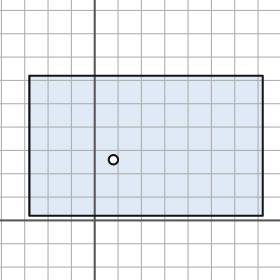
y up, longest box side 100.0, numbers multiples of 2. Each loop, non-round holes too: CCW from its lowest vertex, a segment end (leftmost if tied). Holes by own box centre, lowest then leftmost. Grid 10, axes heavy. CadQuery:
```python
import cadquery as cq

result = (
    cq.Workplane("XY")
    .moveTo(-28.0, 2.0)
    .lineTo(72.0, 2.0)
    .lineTo(72.0, 62.0)
    .lineTo(-28.0, 62.0)
    .close()
    .moveTo(8.0, 26.0)
    .circle(2.0)
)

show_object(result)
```